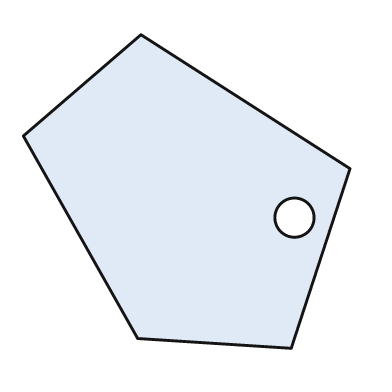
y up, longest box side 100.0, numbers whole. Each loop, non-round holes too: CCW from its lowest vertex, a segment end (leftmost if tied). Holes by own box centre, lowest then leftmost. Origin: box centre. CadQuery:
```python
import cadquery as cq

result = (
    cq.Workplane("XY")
    .moveTo(32.0, -48.0)
    .lineTo(50.0, 7.0)
    .lineTo(-14.0, 48.0)
    .lineTo(-50.0, 17.0)
    .lineTo(-15.0, -45.0)
    .close()
    .moveTo(33.0, -8.0)
    .circle(6.0)
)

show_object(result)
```